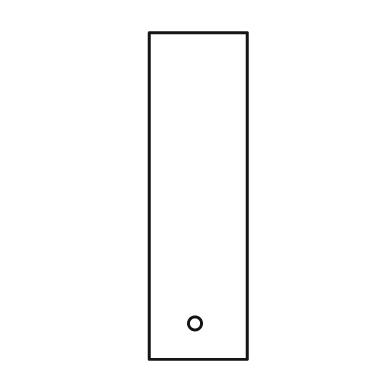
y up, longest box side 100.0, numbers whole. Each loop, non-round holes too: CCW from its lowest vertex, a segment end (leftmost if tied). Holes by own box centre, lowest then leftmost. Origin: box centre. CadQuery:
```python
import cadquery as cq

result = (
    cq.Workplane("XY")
    .moveTo(-15.0, -50.0)
    .lineTo(15.0, -50.0)
    .lineTo(15.0, 50.0)
    .lineTo(-15.0, 50.0)
    .close()
    .moveTo(-1.0, -39.0)
    .circle(2.0)
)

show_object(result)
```